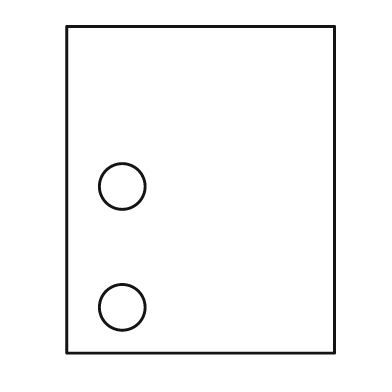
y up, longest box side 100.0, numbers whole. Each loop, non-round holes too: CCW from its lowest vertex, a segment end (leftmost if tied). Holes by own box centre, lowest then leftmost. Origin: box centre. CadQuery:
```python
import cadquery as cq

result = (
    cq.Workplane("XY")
    .moveTo(-41.0, -50.0)
    .lineTo(41.0, -50.0)
    .lineTo(41.0, 50.0)
    .lineTo(-41.0, 50.0)
    .close()
    .moveTo(-24.0, -36.0)
    .circle(7.0)
    .moveTo(-24.0, 1.0)
    .circle(7.0)
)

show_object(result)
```